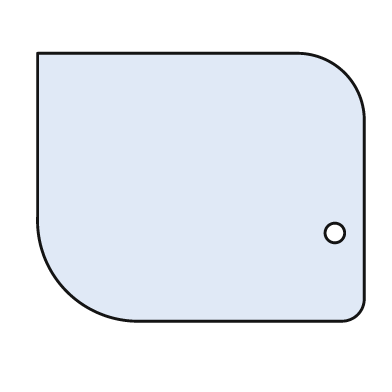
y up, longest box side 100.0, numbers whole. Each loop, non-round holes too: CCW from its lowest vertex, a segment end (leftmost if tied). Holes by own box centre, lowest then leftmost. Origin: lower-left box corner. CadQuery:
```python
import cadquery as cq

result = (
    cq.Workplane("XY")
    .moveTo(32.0, 0.0)
    .lineTo(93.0, 0.0)
    .threePointArc((98.0, 2.0), (100.0, 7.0))
    .lineTo(100.0, 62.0)
    .threePointArc((94.0, 76.0), (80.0, 82.0))
    .lineTo(0.0, 82.0)
    .lineTo(0.0, 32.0)
    .threePointArc((9.0, 9.0), (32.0, 0.0))
    .close()
    .moveTo(91.0, 27.0)
    .circle(3.0)
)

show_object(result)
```